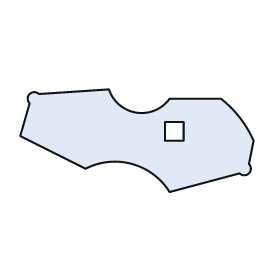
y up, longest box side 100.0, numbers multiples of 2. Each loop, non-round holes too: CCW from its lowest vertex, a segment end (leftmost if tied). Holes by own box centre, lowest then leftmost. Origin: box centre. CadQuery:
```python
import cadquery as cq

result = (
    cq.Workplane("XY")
    .moveTo(14.0, -22.0)
    .lineTo(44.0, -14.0)
    .threePointArc((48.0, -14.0), (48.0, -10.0))
    .lineTo(50.0, 0.0)
    .threePointArc((44.0, 10.0), (36.0, 18.0))
    .lineTo(14.0, 18.0)
    .threePointArc((0.0, 12.0), (-12.0, 22.0))
    .lineTo(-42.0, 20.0)
    .threePointArc((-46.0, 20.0), (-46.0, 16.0))
    .lineTo(-50.0, 2.0)
    .lineTo(-22.0, -12.0)
    .threePointArc((-2.0, -10.0), (14.0, -22.0))
    .close()
    .moveTo(12.0, 0.0)
    .lineTo(20.0, 0.0)
    .lineTo(20.0, 8.0)
    .lineTo(12.0, 8.0)
    .close()
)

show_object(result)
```